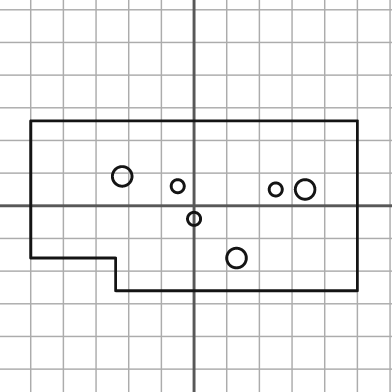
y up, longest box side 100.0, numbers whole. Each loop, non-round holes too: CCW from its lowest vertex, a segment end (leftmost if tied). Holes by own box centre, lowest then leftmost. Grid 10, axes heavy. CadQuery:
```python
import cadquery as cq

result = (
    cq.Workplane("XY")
    .moveTo(-24.0, -26.0)
    .lineTo(50.0, -26.0)
    .lineTo(50.0, 26.0)
    .lineTo(-50.0, 26.0)
    .lineTo(-50.0, -16.0)
    .lineTo(-24.0, -16.0)
    .close()
    .moveTo(13.0, -16.0)
    .circle(3.0)
    .moveTo(0.0, -4.0)
    .circle(2.0)
    .moveTo(25.0, 5.0)
    .circle(2.0)
    .moveTo(34.0, 5.0)
    .circle(3.0)
    .moveTo(-5.0, 6.0)
    .circle(2.0)
    .moveTo(-22.0, 9.0)
    .circle(3.0)
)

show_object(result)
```